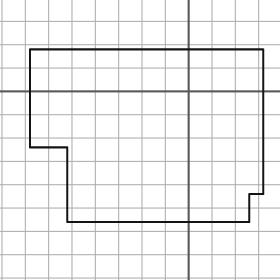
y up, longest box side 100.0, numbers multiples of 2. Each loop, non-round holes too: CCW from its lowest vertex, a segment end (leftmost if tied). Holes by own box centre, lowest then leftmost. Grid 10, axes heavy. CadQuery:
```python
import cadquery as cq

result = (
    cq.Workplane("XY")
    .moveTo(-52.0, -56.0)
    .lineTo(26.0, -56.0)
    .lineTo(26.0, -44.0)
    .lineTo(32.0, -44.0)
    .lineTo(32.0, 18.0)
    .lineTo(-68.0, 18.0)
    .lineTo(-68.0, -24.0)
    .lineTo(-52.0, -24.0)
    .close()
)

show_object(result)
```